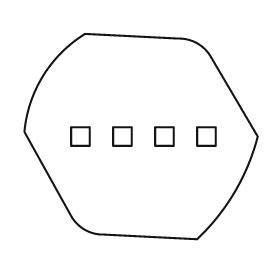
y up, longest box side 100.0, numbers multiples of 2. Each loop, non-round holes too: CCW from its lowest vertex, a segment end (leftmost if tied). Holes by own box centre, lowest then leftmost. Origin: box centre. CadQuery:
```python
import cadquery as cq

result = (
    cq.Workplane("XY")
    .moveTo(24.0, -44.0)
    .threePointArc((40.0, -24.0), (50.0, 0.0))
    .lineTo(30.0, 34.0)
    .threePointArc((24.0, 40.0), (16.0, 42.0))
    .lineTo(-24.0, 44.0)
    .threePointArc((-42.0, 26.0), (-50.0, 2.0))
    .lineTo(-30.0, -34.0)
    .threePointArc((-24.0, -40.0), (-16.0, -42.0))
    .close()
    .moveTo(-30.0, -4.0)
    .lineTo(-22.0, -4.0)
    .lineTo(-22.0, 4.0)
    .lineTo(-30.0, 4.0)
    .close()
    .moveTo(-12.0, -4.0)
    .lineTo(-4.0, -4.0)
    .lineTo(-4.0, 4.0)
    .lineTo(-12.0, 4.0)
    .close()
    .moveTo(6.0, -4.0)
    .lineTo(14.0, -4.0)
    .lineTo(14.0, 4.0)
    .lineTo(6.0, 4.0)
    .close()
    .moveTo(24.0, -4.0)
    .lineTo(32.0, -4.0)
    .lineTo(32.0, 4.0)
    .lineTo(24.0, 4.0)
    .close()
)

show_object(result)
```